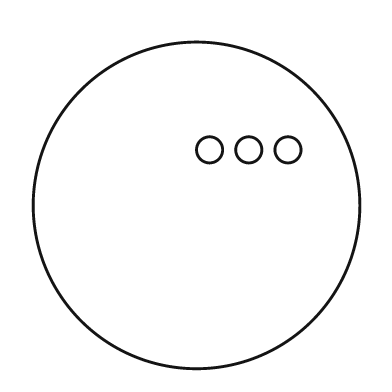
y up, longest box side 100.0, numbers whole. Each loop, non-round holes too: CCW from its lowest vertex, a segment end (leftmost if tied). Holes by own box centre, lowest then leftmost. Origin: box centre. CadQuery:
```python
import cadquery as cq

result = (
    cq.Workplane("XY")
    .moveTo(0.0, 0.0)
    .circle(50.0)
    .moveTo(4.0, 17.0)
    .circle(4.0)
    .moveTo(16.0, 17.0)
    .circle(4.0)
    .moveTo(28.0, 17.0)
    .circle(4.0)
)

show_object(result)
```